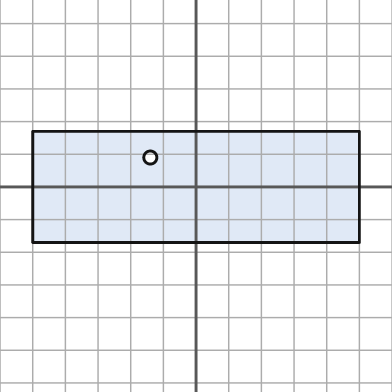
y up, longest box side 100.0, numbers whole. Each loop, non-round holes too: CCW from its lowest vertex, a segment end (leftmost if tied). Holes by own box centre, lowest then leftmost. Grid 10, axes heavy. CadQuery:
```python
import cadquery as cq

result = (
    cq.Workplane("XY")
    .moveTo(-50.0, -17.0)
    .lineTo(50.0, -17.0)
    .lineTo(50.0, 17.0)
    .lineTo(-50.0, 17.0)
    .close()
    .moveTo(-14.0, 9.0)
    .circle(2.0)
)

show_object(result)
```